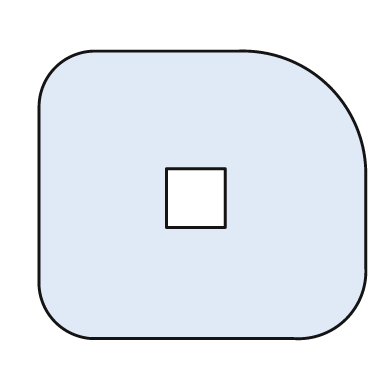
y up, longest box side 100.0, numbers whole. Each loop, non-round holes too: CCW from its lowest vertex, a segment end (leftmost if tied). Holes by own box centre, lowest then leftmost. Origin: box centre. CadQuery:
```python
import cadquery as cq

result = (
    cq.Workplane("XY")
    .moveTo(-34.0, -44.0)
    .lineTo(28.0, -44.0)
    .threePointArc((44.0, -38.0), (50.0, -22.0))
    .lineTo(50.0, 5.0)
    .threePointArc((39.0, 33.0), (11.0, 44.0))
    .lineTo(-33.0, 44.0)
    .threePointArc((-45.0, 39.0), (-50.0, 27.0))
    .lineTo(-50.0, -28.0)
    .threePointArc((-45.0, -39.0), (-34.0, -44.0))
    .close()
    .moveTo(-11.0, -10.0)
    .lineTo(7.0, -10.0)
    .lineTo(7.0, 8.0)
    .lineTo(-11.0, 8.0)
    .close()
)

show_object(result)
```